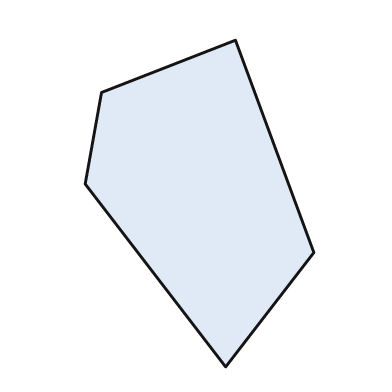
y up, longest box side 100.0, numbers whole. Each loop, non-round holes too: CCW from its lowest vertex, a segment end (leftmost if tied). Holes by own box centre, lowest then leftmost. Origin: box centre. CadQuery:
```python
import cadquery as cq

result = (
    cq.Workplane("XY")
    .moveTo(8.0, -50.0)
    .lineTo(35.0, -15.0)
    .lineTo(11.0, 50.0)
    .lineTo(-30.0, 34.0)
    .lineTo(-35.0, 6.0)
    .close()
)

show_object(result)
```